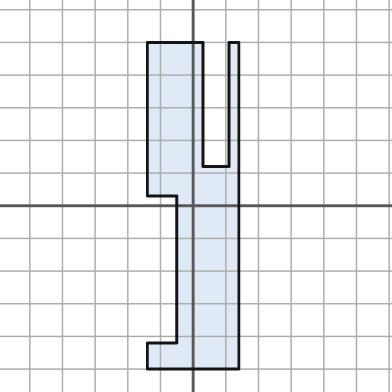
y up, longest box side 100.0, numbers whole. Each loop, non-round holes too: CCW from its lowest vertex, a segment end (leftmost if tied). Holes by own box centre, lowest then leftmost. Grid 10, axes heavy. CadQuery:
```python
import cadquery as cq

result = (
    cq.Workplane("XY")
    .moveTo(-14.0, -50.0)
    .lineTo(14.0, -50.0)
    .lineTo(14.0, 50.0)
    .lineTo(11.0, 50.0)
    .lineTo(11.0, 12.0)
    .lineTo(3.0, 12.0)
    .lineTo(3.0, 50.0)
    .lineTo(-14.0, 50.0)
    .lineTo(-14.0, 3.0)
    .lineTo(-5.0, 3.0)
    .lineTo(-5.0, -42.0)
    .lineTo(-14.0, -42.0)
    .close()
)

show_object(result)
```